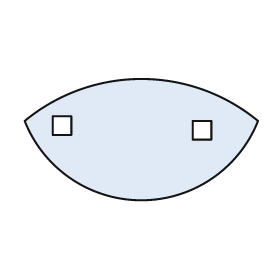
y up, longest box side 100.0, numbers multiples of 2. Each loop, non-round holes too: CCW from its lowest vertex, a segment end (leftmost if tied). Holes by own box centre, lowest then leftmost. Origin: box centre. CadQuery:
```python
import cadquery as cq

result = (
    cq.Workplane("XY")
    .moveTo(-50.0, 8.0)
    .threePointArc((0.0, -26.0), (50.0, 8.0))
    .threePointArc((0.0, 26.0), (-50.0, 8.0))
    .close()
    .moveTo(22.0, 0.0)
    .lineTo(30.0, 0.0)
    .lineTo(30.0, 8.0)
    .lineTo(22.0, 8.0)
    .close()
    .moveTo(-38.0, 2.0)
    .lineTo(-30.0, 2.0)
    .lineTo(-30.0, 10.0)
    .lineTo(-38.0, 10.0)
    .close()
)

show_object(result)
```